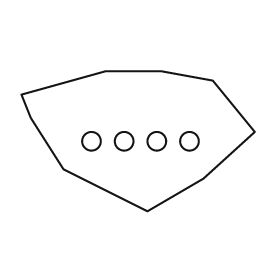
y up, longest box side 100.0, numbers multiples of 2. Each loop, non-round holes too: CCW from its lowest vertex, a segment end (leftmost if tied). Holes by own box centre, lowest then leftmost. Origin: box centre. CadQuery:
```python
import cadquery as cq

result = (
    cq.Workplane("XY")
    .moveTo(4.0, -30.0)
    .lineTo(28.0, -16.0)
    .lineTo(50.0, 4.0)
    .lineTo(32.0, 26.0)
    .lineTo(10.0, 30.0)
    .lineTo(-14.0, 30.0)
    .lineTo(-50.0, 20.0)
    .lineTo(-46.0, 10.0)
    .lineTo(-32.0, -12.0)
    .close()
    .moveTo(-20.0, 0.0)
    .circle(4.0)
    .moveTo(-6.0, 0.0)
    .circle(4.0)
    .moveTo(8.0, 0.0)
    .circle(4.0)
    .moveTo(22.0, 0.0)
    .circle(4.0)
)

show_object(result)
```